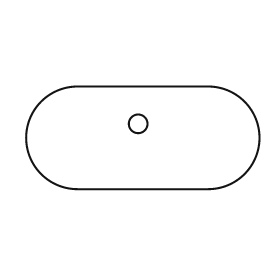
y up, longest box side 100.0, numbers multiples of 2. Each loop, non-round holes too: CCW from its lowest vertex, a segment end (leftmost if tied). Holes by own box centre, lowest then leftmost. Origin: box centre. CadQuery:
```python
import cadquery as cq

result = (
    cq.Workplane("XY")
    .moveTo(-28.0, -22.0)
    .lineTo(28.0, -22.0)
    .threePointArc((50.0, 0.0), (28.0, 22.0))
    .lineTo(-28.0, 22.0)
    .threePointArc((-50.0, 0.0), (-28.0, -22.0))
    .close()
    .moveTo(-2.0, 6.0)
    .circle(4.0)
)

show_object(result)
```